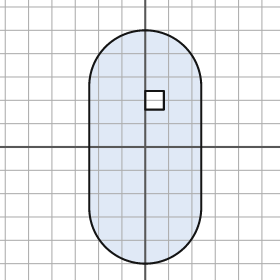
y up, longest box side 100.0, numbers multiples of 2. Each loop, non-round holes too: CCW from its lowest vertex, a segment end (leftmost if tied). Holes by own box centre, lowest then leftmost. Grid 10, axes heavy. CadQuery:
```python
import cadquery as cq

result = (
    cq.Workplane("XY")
    .moveTo(-24.0, -26.0)
    .threePointArc((0.0, -50.0), (24.0, -26.0))
    .lineTo(24.0, 26.0)
    .threePointArc((0.0, 50.0), (-24.0, 26.0))
    .close()
    .moveTo(0.0, 16.0)
    .lineTo(8.0, 16.0)
    .lineTo(8.0, 24.0)
    .lineTo(0.0, 24.0)
    .close()
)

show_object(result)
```